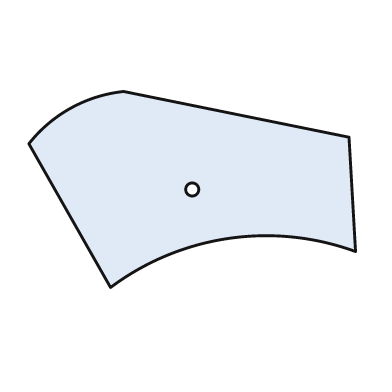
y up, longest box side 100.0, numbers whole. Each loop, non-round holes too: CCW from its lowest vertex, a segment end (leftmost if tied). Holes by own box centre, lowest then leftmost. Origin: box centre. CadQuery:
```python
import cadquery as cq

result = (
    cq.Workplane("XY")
    .moveTo(-25.0, -30.0)
    .threePointArc((11.0, -15.0), (50.0, -19.0))
    .lineTo(48.0, 16.0)
    .lineTo(-21.0, 30.0)
    .threePointArc((-37.0, 25.0), (-50.0, 14.0))
    .close()
    .moveTo(0.0, 0.0)
    .circle(2.0)
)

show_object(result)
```